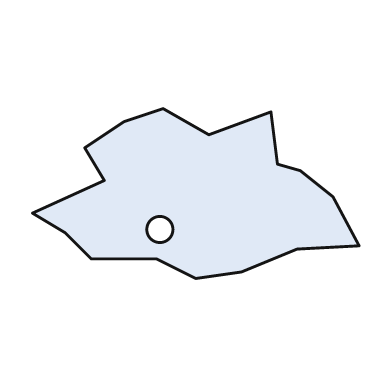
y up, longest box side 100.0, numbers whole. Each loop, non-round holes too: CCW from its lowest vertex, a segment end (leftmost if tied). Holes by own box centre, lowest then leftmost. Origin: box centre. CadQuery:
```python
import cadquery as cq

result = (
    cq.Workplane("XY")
    .moveTo(0.0, -26.0)
    .lineTo(14.0, -24.0)
    .lineTo(31.0, -17.0)
    .lineTo(50.0, -16.0)
    .lineTo(42.0, -1.0)
    .lineTo(32.0, 7.0)
    .lineTo(25.0, 9.0)
    .lineTo(23.0, 25.0)
    .lineTo(4.0, 18.0)
    .lineTo(-10.0, 26.0)
    .lineTo(-22.0, 22.0)
    .lineTo(-34.0, 14.0)
    .lineTo(-28.0, 4.0)
    .lineTo(-50.0, -6.0)
    .lineTo(-40.0, -12.0)
    .lineTo(-32.0, -20.0)
    .lineTo(-12.0, -20.0)
    .close()
    .moveTo(-11.0, -11.0)
    .circle(4.0)
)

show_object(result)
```